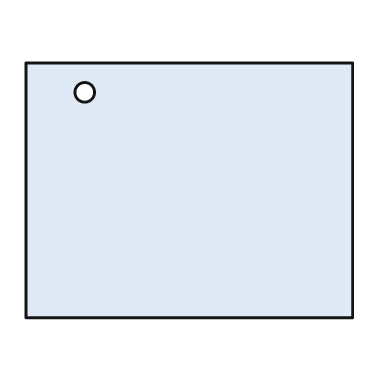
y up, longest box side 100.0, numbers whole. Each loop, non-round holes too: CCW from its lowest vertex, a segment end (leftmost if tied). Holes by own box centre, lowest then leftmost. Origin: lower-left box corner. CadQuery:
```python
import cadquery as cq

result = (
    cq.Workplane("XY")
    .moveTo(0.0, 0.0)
    .lineTo(100.0, 0.0)
    .lineTo(100.0, 78.0)
    .lineTo(0.0, 78.0)
    .close()
    .moveTo(18.0, 69.0)
    .circle(3.0)
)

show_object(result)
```